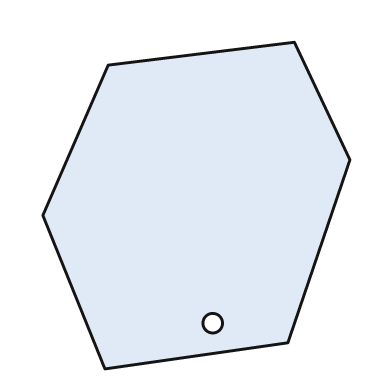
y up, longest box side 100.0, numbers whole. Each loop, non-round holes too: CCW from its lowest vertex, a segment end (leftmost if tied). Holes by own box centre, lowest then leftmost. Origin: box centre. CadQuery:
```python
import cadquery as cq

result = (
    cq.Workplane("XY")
    .moveTo(-28.0, -50.0)
    .lineTo(28.0, -42.0)
    .lineTo(47.0, 14.0)
    .lineTo(30.0, 50.0)
    .lineTo(-27.0, 43.0)
    .lineTo(-47.0, -3.0)
    .close()
    .moveTo(5.0, -36.0)
    .circle(3.0)
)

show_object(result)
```